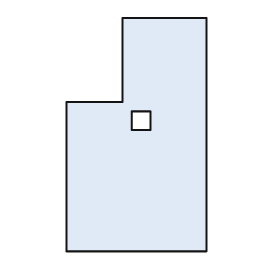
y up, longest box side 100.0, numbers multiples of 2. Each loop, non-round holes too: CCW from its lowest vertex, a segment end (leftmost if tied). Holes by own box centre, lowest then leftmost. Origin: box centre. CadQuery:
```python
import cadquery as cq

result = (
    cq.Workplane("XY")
    .moveTo(-30.0, -50.0)
    .lineTo(30.0, -50.0)
    .lineTo(30.0, 50.0)
    .lineTo(-6.0, 50.0)
    .lineTo(-6.0, 14.0)
    .lineTo(-30.0, 14.0)
    .close()
    .moveTo(-2.0, 2.0)
    .lineTo(6.0, 2.0)
    .lineTo(6.0, 10.0)
    .lineTo(-2.0, 10.0)
    .close()
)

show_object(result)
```